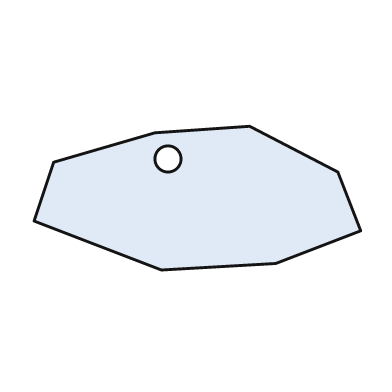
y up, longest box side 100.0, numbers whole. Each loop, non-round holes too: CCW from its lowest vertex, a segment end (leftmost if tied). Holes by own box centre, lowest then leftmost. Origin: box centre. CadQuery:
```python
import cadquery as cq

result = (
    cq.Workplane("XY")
    .moveTo(-11.0, -22.0)
    .lineTo(24.0, -20.0)
    .lineTo(50.0, -10.0)
    .lineTo(43.0, 8.0)
    .lineTo(16.0, 22.0)
    .lineTo(-13.0, 20.0)
    .lineTo(-44.0, 11.0)
    .lineTo(-50.0, -7.0)
    .close()
    .moveTo(-9.0, 12.0)
    .circle(4.0)
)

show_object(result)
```